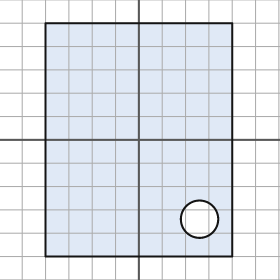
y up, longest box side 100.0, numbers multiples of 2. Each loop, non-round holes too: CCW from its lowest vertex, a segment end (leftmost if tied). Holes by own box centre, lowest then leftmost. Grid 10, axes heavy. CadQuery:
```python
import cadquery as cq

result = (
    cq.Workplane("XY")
    .moveTo(-40.0, -50.0)
    .lineTo(40.0, -50.0)
    .lineTo(40.0, 50.0)
    .lineTo(-40.0, 50.0)
    .close()
    .moveTo(26.0, -34.0)
    .circle(8.0)
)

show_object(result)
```